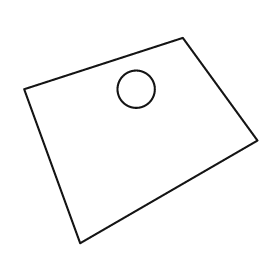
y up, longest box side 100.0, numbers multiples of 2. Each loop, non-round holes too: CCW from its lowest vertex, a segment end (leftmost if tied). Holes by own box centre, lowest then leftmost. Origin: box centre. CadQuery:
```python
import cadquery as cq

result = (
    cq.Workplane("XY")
    .moveTo(-26.0, -44.0)
    .lineTo(50.0, 0.0)
    .lineTo(18.0, 44.0)
    .lineTo(-50.0, 22.0)
    .close()
    .moveTo(-2.0, 22.0)
    .circle(8.0)
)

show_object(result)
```